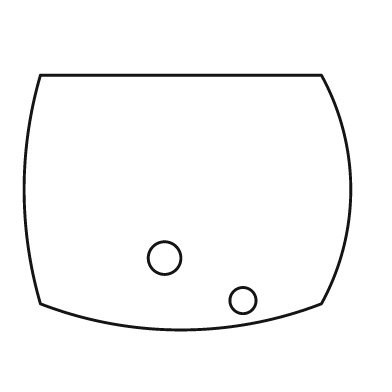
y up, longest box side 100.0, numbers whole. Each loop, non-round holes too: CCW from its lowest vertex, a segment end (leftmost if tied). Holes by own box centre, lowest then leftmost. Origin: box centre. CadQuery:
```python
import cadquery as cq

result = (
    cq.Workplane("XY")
    .moveTo(-45.0, -31.0)
    .threePointArc((-2.0, -39.0), (41.0, -31.0))
    .threePointArc((50.0, 4.0), (41.0, 39.0))
    .lineTo(-45.0, 39.0)
    .threePointArc((-50.0, 4.0), (-45.0, -31.0))
    .close()
    .moveTo(17.0, -30.0)
    .circle(4.0)
    .moveTo(-7.0, -17.0)
    .circle(5.0)
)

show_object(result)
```